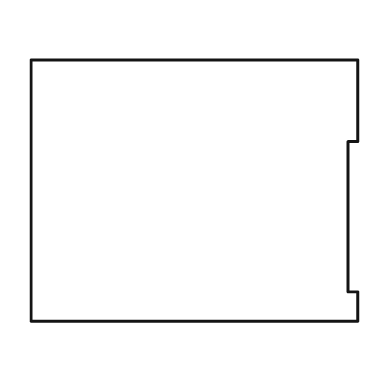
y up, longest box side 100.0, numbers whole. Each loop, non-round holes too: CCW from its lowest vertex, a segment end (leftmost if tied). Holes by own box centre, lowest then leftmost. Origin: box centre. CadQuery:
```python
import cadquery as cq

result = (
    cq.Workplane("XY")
    .moveTo(-50.0, -40.0)
    .lineTo(50.0, -40.0)
    .lineTo(50.0, -31.0)
    .lineTo(47.0, -31.0)
    .lineTo(47.0, 15.0)
    .lineTo(50.0, 15.0)
    .lineTo(50.0, 40.0)
    .lineTo(-50.0, 40.0)
    .close()
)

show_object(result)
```